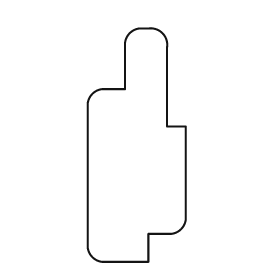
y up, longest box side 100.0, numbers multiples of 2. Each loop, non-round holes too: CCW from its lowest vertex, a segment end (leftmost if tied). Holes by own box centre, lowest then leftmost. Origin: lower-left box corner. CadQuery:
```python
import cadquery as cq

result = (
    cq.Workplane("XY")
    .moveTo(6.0, 0.0)
    .lineTo(26.0, 0.0)
    .lineTo(26.0, 12.0)
    .lineTo(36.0, 12.0)
    .threePointArc((40.0, 14.0), (42.0, 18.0))
    .lineTo(42.0, 58.0)
    .lineTo(34.0, 58.0)
    .lineTo(34.0, 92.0)
    .threePointArc((32.0, 98.0), (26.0, 100.0))
    .lineTo(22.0, 100.0)
    .threePointArc((18.0, 98.0), (16.0, 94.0))
    .lineTo(16.0, 74.0)
    .lineTo(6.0, 74.0)
    .threePointArc((2.0, 72.0), (0.0, 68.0))
    .lineTo(0.0, 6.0)
    .threePointArc((2.0, 2.0), (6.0, 0.0))
    .close()
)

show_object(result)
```